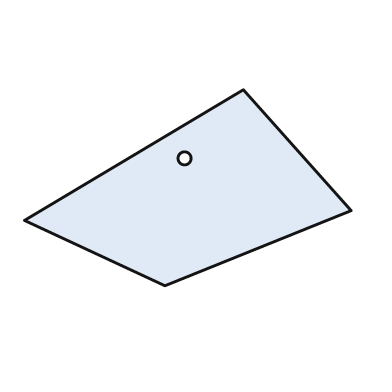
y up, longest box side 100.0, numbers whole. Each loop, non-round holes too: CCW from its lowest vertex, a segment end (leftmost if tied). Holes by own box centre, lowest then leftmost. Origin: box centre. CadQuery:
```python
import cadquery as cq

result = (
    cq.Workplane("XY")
    .moveTo(-7.0, -30.0)
    .lineTo(50.0, -7.0)
    .lineTo(17.0, 30.0)
    .lineTo(-50.0, -10.0)
    .close()
    .moveTo(-1.0, 9.0)
    .circle(2.0)
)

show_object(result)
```